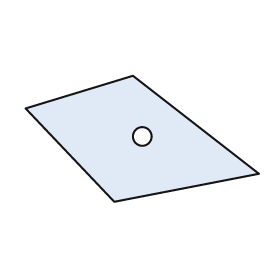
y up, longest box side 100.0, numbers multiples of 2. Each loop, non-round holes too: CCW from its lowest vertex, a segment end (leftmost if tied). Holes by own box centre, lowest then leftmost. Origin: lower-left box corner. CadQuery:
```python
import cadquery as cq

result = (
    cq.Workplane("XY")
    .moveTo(38.0, 0.0)
    .lineTo(100.0, 12.0)
    .lineTo(46.0, 54.0)
    .lineTo(0.0, 40.0)
    .close()
    .moveTo(50.0, 28.0)
    .circle(4.0)
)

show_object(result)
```